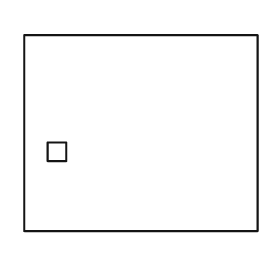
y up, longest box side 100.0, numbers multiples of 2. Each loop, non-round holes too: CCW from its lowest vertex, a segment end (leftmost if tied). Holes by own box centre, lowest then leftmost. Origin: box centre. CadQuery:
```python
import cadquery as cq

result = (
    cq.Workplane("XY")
    .moveTo(-50.0, -42.0)
    .lineTo(50.0, -42.0)
    .lineTo(50.0, 42.0)
    .lineTo(-50.0, 42.0)
    .close()
    .moveTo(-40.0, -12.0)
    .lineTo(-32.0, -12.0)
    .lineTo(-32.0, -4.0)
    .lineTo(-40.0, -4.0)
    .close()
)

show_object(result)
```